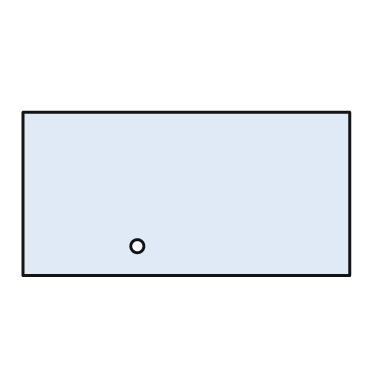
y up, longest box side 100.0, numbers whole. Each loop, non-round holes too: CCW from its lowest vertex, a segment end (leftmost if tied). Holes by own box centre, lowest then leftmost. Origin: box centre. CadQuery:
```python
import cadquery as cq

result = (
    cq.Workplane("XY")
    .moveTo(-50.0, -25.0)
    .lineTo(50.0, -25.0)
    .lineTo(50.0, 25.0)
    .lineTo(-50.0, 25.0)
    .close()
    .moveTo(-15.0, -16.0)
    .circle(2.0)
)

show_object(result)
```